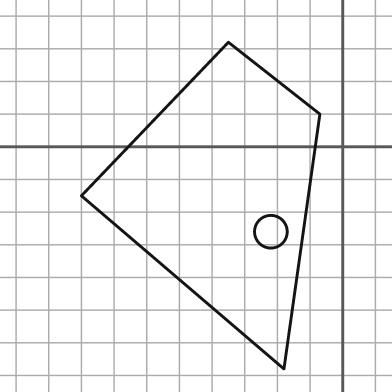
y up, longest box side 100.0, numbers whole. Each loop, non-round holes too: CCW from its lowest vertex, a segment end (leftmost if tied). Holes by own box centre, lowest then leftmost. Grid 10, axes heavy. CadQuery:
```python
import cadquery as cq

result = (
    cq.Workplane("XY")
    .moveTo(-18.0, -68.0)
    .lineTo(-7.0, 10.0)
    .lineTo(-35.0, 32.0)
    .lineTo(-80.0, -15.0)
    .close()
    .moveTo(-22.0, -26.0)
    .circle(5.0)
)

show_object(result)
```